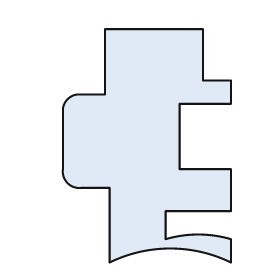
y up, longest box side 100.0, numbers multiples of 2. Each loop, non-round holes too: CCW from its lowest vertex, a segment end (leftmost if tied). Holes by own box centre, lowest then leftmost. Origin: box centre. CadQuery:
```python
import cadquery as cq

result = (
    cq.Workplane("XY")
    .moveTo(-16.0, -50.0)
    .threePointArc((10.0, -44.0), (36.0, -50.0))
    .lineTo(36.0, -40.0)
    .threePointArc((22.0, -38.0), (8.0, -40.0))
    .lineTo(8.0, -28.0)
    .lineTo(36.0, -28.0)
    .lineTo(36.0, -10.0)
    .lineTo(14.0, -10.0)
    .lineTo(14.0, 18.0)
    .lineTo(36.0, 18.0)
    .lineTo(36.0, 28.0)
    .lineTo(24.0, 28.0)
    .lineTo(24.0, 50.0)
    .lineTo(-18.0, 50.0)
    .lineTo(-18.0, 22.0)
    .lineTo(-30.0, 22.0)
    .threePointArc((-34.0, 20.0), (-36.0, 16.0))
    .lineTo(-36.0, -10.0)
    .threePointArc((-34.0, -16.0), (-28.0, -18.0))
    .lineTo(-16.0, -18.0)
    .close()
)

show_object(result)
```